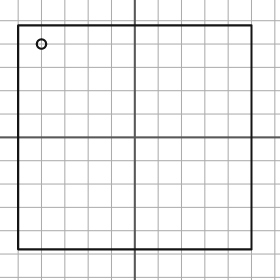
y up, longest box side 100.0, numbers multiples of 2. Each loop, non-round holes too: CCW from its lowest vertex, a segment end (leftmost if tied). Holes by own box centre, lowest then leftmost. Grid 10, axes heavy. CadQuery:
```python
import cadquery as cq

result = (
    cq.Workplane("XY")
    .moveTo(-50.0, -48.0)
    .lineTo(50.0, -48.0)
    .lineTo(50.0, 48.0)
    .lineTo(-50.0, 48.0)
    .close()
    .moveTo(-40.0, 40.0)
    .circle(2.0)
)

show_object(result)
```